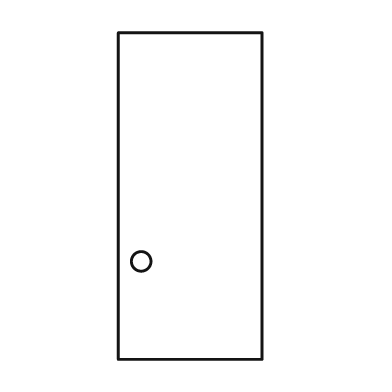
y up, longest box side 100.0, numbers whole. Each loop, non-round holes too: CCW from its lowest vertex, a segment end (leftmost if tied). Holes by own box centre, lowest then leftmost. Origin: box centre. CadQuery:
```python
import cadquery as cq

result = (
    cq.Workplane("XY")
    .moveTo(-22.0, -50.0)
    .lineTo(22.0, -50.0)
    .lineTo(22.0, 50.0)
    .lineTo(-22.0, 50.0)
    .close()
    .moveTo(-15.0, -20.0)
    .circle(3.0)
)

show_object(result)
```